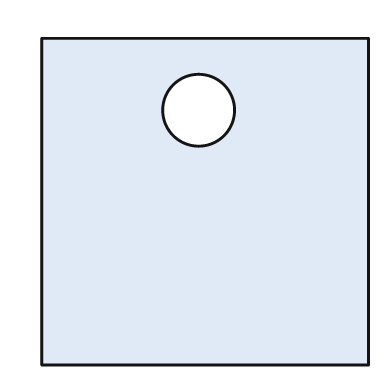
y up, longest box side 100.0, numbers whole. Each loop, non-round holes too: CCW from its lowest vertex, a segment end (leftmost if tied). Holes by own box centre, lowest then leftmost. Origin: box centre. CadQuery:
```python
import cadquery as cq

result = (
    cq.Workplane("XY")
    .moveTo(-50.0, -50.0)
    .lineTo(50.0, -50.0)
    .lineTo(50.0, 50.0)
    .lineTo(-50.0, 50.0)
    .close()
    .moveTo(-2.0, 28.0)
    .circle(11.0)
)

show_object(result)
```